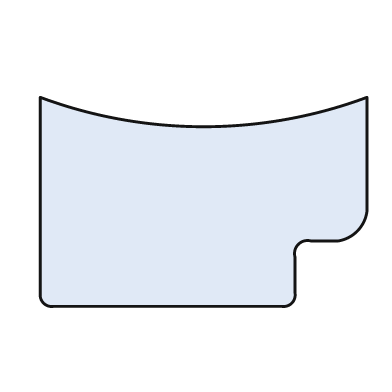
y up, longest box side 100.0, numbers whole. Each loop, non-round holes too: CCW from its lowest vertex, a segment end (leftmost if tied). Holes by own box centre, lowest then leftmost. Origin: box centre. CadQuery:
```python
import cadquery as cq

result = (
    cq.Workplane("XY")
    .moveTo(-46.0, -32.0)
    .lineTo(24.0, -32.0)
    .threePointArc((27.0, -31.0), (28.0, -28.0))
    .lineTo(28.0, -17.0)
    .threePointArc((29.0, -13.0), (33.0, -12.0))
    .lineTo(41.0, -12.0)
    .threePointArc((47.0, -9.0), (50.0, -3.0))
    .lineTo(50.0, 32.0)
    .threePointArc((0.0, 23.0), (-50.0, 32.0))
    .lineTo(-50.0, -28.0)
    .threePointArc((-49.0, -31.0), (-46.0, -32.0))
    .close()
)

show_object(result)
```